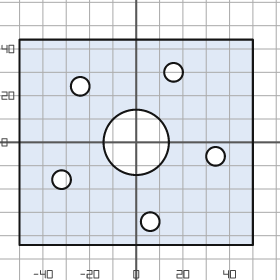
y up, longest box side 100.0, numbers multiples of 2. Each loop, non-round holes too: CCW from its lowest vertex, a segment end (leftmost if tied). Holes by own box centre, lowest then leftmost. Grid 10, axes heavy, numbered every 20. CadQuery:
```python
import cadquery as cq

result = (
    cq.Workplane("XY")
    .moveTo(-50.0, -44.0)
    .lineTo(50.0, -44.0)
    .lineTo(50.0, 44.0)
    .lineTo(-50.0, 44.0)
    .close()
    .moveTo(6.0, -34.0)
    .circle(4.0)
    .moveTo(-32.0, -16.0)
    .circle(4.0)
    .moveTo(34.0, -6.0)
    .circle(4.0)
    .moveTo(0.0, 0.0)
    .circle(14.0)
    .moveTo(-24.0, 24.0)
    .circle(4.0)
    .moveTo(16.0, 30.0)
    .circle(4.0)
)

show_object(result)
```